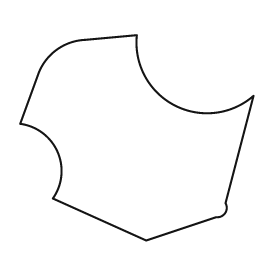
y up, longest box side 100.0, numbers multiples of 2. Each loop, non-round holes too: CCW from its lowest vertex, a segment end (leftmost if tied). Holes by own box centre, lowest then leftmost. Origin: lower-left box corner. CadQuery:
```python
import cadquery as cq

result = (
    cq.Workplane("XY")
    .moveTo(54.0, 0.0)
    .lineTo(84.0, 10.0)
    .threePointArc((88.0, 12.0), (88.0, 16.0))
    .lineTo(100.0, 62.0)
    .threePointArc((66.0, 58.0), (50.0, 88.0))
    .lineTo(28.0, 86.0)
    .threePointArc((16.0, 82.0), (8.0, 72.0))
    .lineTo(0.0, 50.0)
    .threePointArc((16.0, 38.0), (14.0, 18.0))
    .close()
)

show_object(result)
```